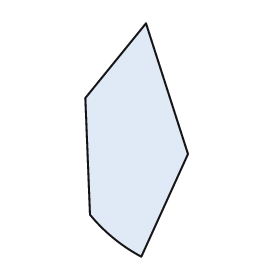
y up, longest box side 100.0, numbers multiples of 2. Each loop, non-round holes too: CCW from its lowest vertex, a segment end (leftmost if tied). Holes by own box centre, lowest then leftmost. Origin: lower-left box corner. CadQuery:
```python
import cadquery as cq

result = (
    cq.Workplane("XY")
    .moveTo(24.0, 0.0)
    .lineTo(44.0, 44.0)
    .lineTo(26.0, 100.0)
    .lineTo(0.0, 68.0)
    .lineTo(2.0, 18.0)
    .threePointArc((12.0, 8.0), (24.0, 0.0))
    .close()
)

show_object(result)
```